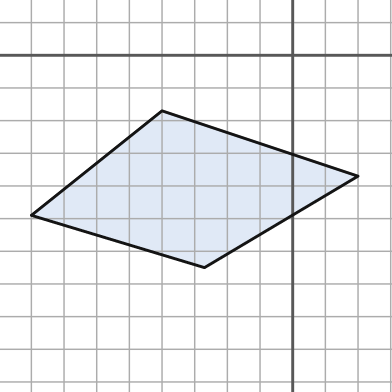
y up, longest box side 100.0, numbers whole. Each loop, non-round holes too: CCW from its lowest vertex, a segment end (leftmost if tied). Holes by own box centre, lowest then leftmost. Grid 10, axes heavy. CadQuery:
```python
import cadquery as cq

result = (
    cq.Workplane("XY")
    .moveTo(-27.0, -65.0)
    .lineTo(20.0, -37.0)
    .lineTo(-40.0, -17.0)
    .lineTo(-80.0, -49.0)
    .close()
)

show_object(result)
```